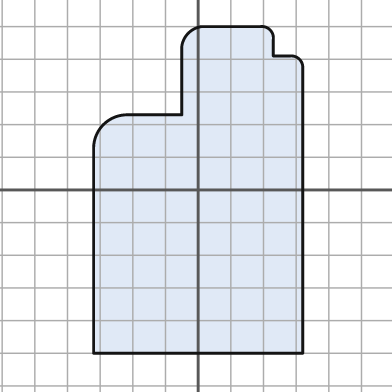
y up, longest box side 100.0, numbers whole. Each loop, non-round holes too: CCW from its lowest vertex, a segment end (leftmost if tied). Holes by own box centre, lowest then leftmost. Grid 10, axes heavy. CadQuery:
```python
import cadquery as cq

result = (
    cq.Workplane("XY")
    .moveTo(-32.0, -50.0)
    .lineTo(32.0, -50.0)
    .lineTo(32.0, 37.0)
    .threePointArc((31.0, 40.0), (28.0, 41.0))
    .lineTo(23.0, 41.0)
    .lineTo(23.0, 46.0)
    .threePointArc((22.0, 49.0), (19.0, 50.0))
    .lineTo(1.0, 50.0)
    .threePointArc((-3.0, 48.0), (-5.0, 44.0))
    .lineTo(-5.0, 23.0)
    .lineTo(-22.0, 23.0)
    .threePointArc((-29.0, 20.0), (-32.0, 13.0))
    .close()
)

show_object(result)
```